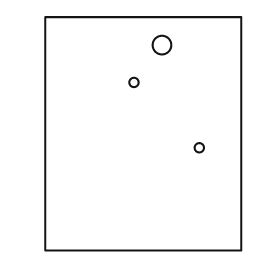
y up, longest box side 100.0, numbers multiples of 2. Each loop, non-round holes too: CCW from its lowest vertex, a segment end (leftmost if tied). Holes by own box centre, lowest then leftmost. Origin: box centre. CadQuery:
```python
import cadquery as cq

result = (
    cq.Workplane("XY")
    .moveTo(-42.0, -50.0)
    .lineTo(42.0, -50.0)
    .lineTo(42.0, 50.0)
    .lineTo(-42.0, 50.0)
    .close()
    .moveTo(24.0, -6.0)
    .circle(2.0)
    .moveTo(-4.0, 22.0)
    .circle(2.0)
    .moveTo(8.0, 38.0)
    .circle(4.0)
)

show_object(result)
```